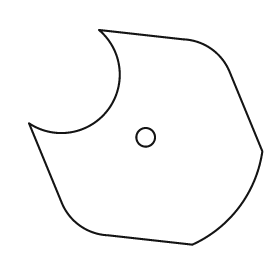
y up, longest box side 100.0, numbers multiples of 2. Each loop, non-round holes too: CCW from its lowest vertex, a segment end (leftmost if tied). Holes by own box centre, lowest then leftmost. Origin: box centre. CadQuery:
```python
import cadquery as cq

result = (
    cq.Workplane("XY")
    .moveTo(20.0, -46.0)
    .threePointArc((40.0, -30.0), (50.0, -6.0))
    .lineTo(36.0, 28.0)
    .threePointArc((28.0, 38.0), (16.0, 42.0))
    .lineTo(-20.0, 46.0)
    .threePointArc((-16.0, 12.0), (-50.0, 6.0))
    .lineTo(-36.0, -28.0)
    .threePointArc((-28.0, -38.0), (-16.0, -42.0))
    .close()
    .moveTo(0.0, 0.0)
    .circle(4.0)
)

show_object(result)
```